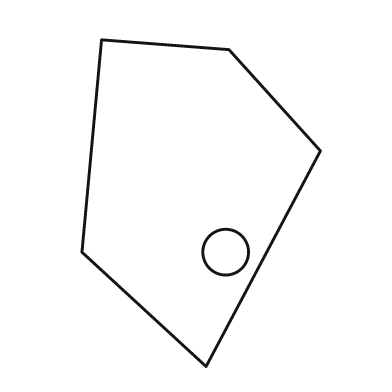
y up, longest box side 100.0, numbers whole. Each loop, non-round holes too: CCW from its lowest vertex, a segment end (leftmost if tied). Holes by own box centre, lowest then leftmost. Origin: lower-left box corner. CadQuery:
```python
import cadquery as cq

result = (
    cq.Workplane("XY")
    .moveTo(38.0, 0.0)
    .lineTo(73.0, 66.0)
    .lineTo(45.0, 97.0)
    .lineTo(6.0, 100.0)
    .lineTo(0.0, 35.0)
    .close()
    .moveTo(44.0, 35.0)
    .circle(7.0)
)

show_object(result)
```